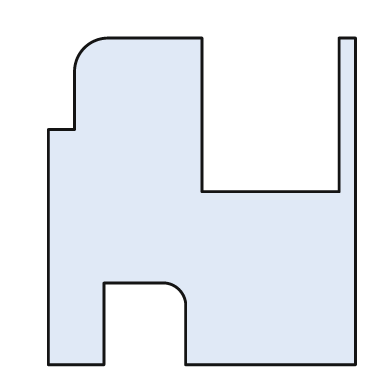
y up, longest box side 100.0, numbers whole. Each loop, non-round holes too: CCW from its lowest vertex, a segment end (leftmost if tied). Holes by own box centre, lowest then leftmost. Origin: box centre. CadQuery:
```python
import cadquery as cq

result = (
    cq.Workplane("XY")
    .moveTo(-47.0, -50.0)
    .lineTo(-30.0, -50.0)
    .lineTo(-30.0, -25.0)
    .lineTo(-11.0, -25.0)
    .threePointArc((-7.0, -27.0), (-5.0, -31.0))
    .lineTo(-5.0, -50.0)
    .lineTo(47.0, -50.0)
    .lineTo(47.0, 50.0)
    .lineTo(42.0, 50.0)
    .lineTo(42.0, 3.0)
    .lineTo(0.0, 3.0)
    .lineTo(0.0, 50.0)
    .lineTo(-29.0, 50.0)
    .threePointArc((-36.0, 47.0), (-39.0, 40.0))
    .lineTo(-39.0, 22.0)
    .lineTo(-47.0, 22.0)
    .close()
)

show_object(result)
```